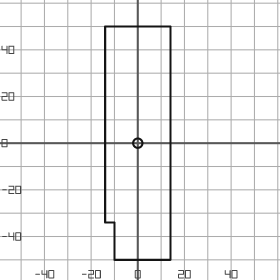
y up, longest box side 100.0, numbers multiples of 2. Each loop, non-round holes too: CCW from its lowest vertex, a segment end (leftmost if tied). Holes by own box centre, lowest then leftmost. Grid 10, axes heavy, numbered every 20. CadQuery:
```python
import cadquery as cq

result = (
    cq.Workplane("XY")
    .moveTo(-10.0, -50.0)
    .lineTo(14.0, -50.0)
    .lineTo(14.0, 50.0)
    .lineTo(-14.0, 50.0)
    .lineTo(-14.0, -34.0)
    .lineTo(-10.0, -34.0)
    .close()
    .moveTo(0.0, 0.0)
    .circle(2.0)
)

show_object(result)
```